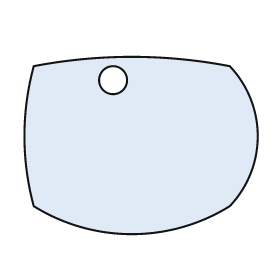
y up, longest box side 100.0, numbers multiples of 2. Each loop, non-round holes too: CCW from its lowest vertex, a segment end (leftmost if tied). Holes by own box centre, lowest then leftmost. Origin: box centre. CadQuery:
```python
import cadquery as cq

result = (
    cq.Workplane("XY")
    .moveTo(-46.0, -26.0)
    .threePointArc((-4.0, -38.0), (38.0, -26.0))
    .threePointArc((50.0, 4.0), (38.0, 34.0))
    .threePointArc((-4.0, 38.0), (-46.0, 34.0))
    .threePointArc((-50.0, 4.0), (-46.0, -26.0))
    .close()
    .moveTo(-12.0, 28.0)
    .circle(6.0)
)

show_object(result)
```